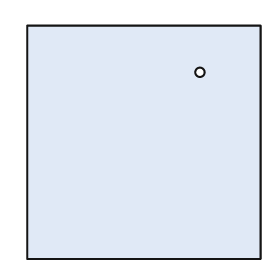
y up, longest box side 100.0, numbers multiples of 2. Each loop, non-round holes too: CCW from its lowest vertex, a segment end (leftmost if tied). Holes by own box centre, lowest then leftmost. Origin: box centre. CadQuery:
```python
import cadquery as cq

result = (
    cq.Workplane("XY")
    .moveTo(-50.0, -50.0)
    .lineTo(50.0, -50.0)
    .lineTo(50.0, 50.0)
    .lineTo(-50.0, 50.0)
    .close()
    .moveTo(24.0, 30.0)
    .circle(2.0)
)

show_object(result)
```